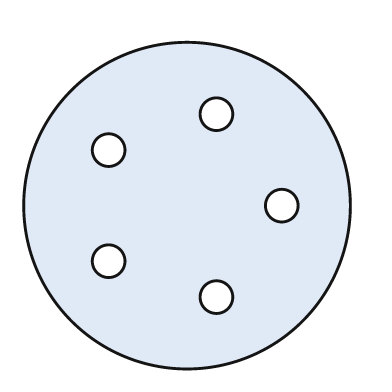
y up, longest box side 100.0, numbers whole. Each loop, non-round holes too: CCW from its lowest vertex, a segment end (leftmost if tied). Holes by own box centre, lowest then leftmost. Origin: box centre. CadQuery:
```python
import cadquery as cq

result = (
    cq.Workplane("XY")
    .moveTo(0.0, 0.0)
    .circle(50.0)
    .moveTo(9.0, -28.0)
    .circle(5.0)
    .moveTo(-24.0, -17.0)
    .circle(5.0)
    .moveTo(29.0, 0.0)
    .circle(5.0)
    .moveTo(-24.0, 17.0)
    .circle(5.0)
    .moveTo(9.0, 28.0)
    .circle(5.0)
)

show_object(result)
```